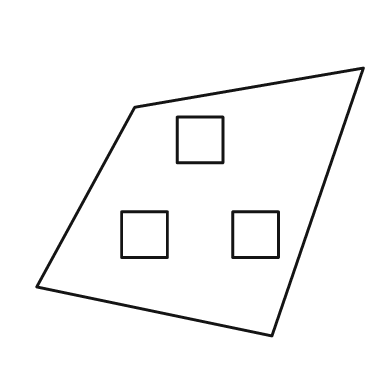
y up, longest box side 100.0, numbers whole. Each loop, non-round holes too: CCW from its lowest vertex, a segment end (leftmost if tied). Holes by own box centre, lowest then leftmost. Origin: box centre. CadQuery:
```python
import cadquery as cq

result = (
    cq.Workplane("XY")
    .moveTo(22.0, -41.0)
    .lineTo(50.0, 41.0)
    .lineTo(-20.0, 29.0)
    .lineTo(-50.0, -26.0)
    .close()
    .moveTo(-24.0, -17.0)
    .lineTo(-10.0, -17.0)
    .lineTo(-10.0, -3.0)
    .lineTo(-24.0, -3.0)
    .close()
    .moveTo(10.0, -17.0)
    .lineTo(24.0, -17.0)
    .lineTo(24.0, -3.0)
    .lineTo(10.0, -3.0)
    .close()
    .moveTo(-7.0, 12.0)
    .lineTo(7.0, 12.0)
    .lineTo(7.0, 26.0)
    .lineTo(-7.0, 26.0)
    .close()
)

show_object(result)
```